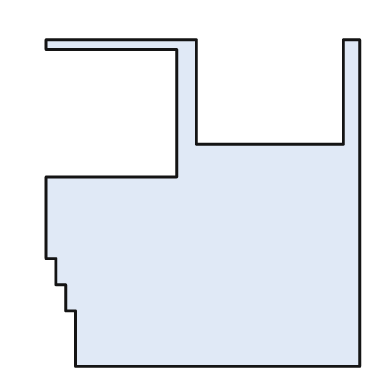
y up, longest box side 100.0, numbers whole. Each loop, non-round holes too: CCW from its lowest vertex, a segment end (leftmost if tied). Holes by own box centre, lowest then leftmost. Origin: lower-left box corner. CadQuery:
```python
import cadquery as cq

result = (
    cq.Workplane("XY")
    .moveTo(9.0, 0.0)
    .lineTo(96.0, 0.0)
    .lineTo(96.0, 100.0)
    .lineTo(91.0, 100.0)
    .lineTo(91.0, 68.0)
    .lineTo(46.0, 68.0)
    .lineTo(46.0, 100.0)
    .lineTo(0.0, 100.0)
    .lineTo(0.0, 97.0)
    .lineTo(40.0, 97.0)
    .lineTo(40.0, 58.0)
    .lineTo(0.0, 58.0)
    .lineTo(0.0, 33.0)
    .lineTo(3.0, 33.0)
    .lineTo(3.0, 25.0)
    .lineTo(6.0, 25.0)
    .lineTo(6.0, 17.0)
    .lineTo(9.0, 17.0)
    .close()
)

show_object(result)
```